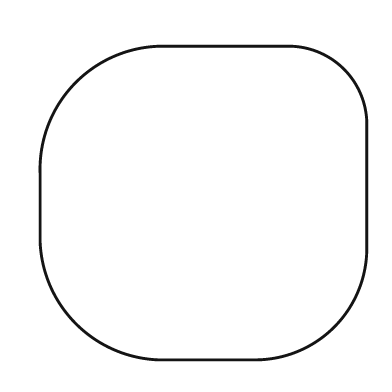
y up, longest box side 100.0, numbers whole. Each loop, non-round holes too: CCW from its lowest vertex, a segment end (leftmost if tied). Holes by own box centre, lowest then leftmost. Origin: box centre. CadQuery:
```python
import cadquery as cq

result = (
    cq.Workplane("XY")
    .moveTo(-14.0, -48.0)
    .lineTo(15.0, -48.0)
    .threePointArc((40.0, -38.0), (50.0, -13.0))
    .lineTo(50.0, 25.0)
    .threePointArc((43.0, 41.0), (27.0, 48.0))
    .lineTo(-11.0, 48.0)
    .threePointArc((-39.0, 37.0), (-50.0, 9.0))
    .lineTo(-50.0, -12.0)
    .threePointArc((-39.0, -37.0), (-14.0, -48.0))
    .close()
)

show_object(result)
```